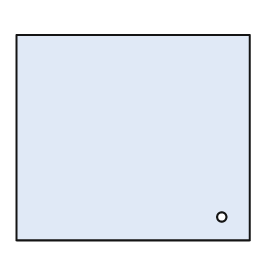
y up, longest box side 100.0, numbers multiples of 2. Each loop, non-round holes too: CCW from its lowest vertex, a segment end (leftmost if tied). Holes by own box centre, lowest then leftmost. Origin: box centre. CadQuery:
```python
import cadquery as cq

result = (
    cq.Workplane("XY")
    .moveTo(-50.0, -44.0)
    .lineTo(50.0, -44.0)
    .lineTo(50.0, 44.0)
    .lineTo(-50.0, 44.0)
    .close()
    .moveTo(38.0, -34.0)
    .circle(2.0)
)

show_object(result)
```